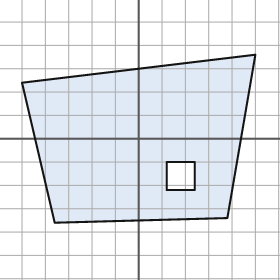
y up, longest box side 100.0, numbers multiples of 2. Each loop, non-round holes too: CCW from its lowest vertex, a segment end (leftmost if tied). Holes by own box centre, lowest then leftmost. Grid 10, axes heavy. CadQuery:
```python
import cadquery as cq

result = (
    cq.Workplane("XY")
    .moveTo(-36.0, -36.0)
    .lineTo(38.0, -34.0)
    .lineTo(50.0, 36.0)
    .lineTo(-50.0, 24.0)
    .close()
    .moveTo(12.0, -22.0)
    .lineTo(24.0, -22.0)
    .lineTo(24.0, -10.0)
    .lineTo(12.0, -10.0)
    .close()
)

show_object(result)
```